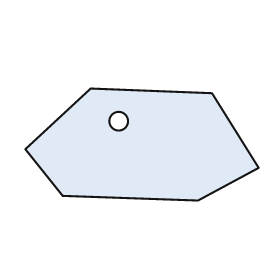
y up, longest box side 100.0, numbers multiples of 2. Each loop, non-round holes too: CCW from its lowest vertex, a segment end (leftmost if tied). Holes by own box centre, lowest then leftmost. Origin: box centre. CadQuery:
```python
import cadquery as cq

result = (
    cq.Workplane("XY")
    .moveTo(24.0, -24.0)
    .lineTo(50.0, -10.0)
    .lineTo(30.0, 22.0)
    .lineTo(-22.0, 24.0)
    .lineTo(-50.0, -2.0)
    .lineTo(-34.0, -22.0)
    .close()
    .moveTo(-10.0, 10.0)
    .circle(4.0)
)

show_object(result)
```